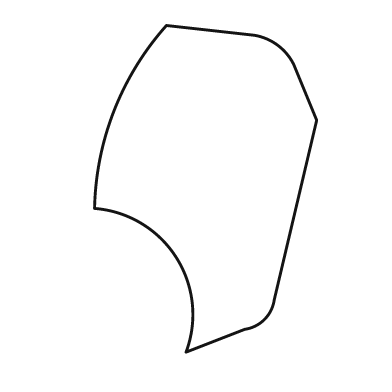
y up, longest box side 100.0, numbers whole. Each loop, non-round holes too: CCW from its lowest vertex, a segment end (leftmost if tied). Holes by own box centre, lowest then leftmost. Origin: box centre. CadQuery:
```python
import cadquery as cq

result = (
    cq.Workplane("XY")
    .moveTo(-6.0, -50.0)
    .lineTo(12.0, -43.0)
    .threePointArc((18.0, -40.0), (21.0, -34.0))
    .lineTo(34.0, 21.0)
    .lineTo(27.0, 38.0)
    .threePointArc((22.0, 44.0), (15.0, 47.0))
    .lineTo(-12.0, 50.0)
    .threePointArc((-28.0, 24.0), (-34.0, -6.0))
    .threePointArc((-9.0, -21.0), (-6.0, -50.0))
    .close()
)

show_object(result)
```